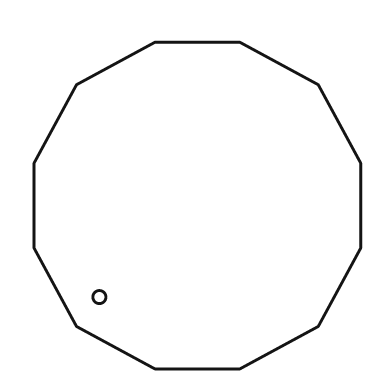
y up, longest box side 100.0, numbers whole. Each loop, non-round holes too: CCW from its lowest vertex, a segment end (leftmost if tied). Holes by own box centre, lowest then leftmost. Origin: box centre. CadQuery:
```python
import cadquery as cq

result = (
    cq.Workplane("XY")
    .moveTo(-13.0, -50.0)
    .lineTo(13.0, -50.0)
    .lineTo(37.0, -37.0)
    .lineTo(50.0, -13.0)
    .lineTo(50.0, 13.0)
    .lineTo(37.0, 37.0)
    .lineTo(13.0, 50.0)
    .lineTo(-13.0, 50.0)
    .lineTo(-37.0, 37.0)
    .lineTo(-50.0, 13.0)
    .lineTo(-50.0, -13.0)
    .lineTo(-37.0, -37.0)
    .close()
    .moveTo(-30.0, -28.0)
    .circle(2.0)
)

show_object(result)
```